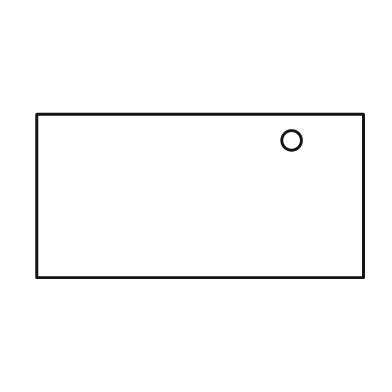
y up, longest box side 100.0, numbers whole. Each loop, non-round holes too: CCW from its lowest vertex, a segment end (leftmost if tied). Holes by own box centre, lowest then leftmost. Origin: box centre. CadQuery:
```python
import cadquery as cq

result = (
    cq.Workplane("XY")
    .moveTo(-50.0, -25.0)
    .lineTo(50.0, -25.0)
    .lineTo(50.0, 25.0)
    .lineTo(-50.0, 25.0)
    .close()
    .moveTo(28.0, 17.0)
    .circle(3.0)
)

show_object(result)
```